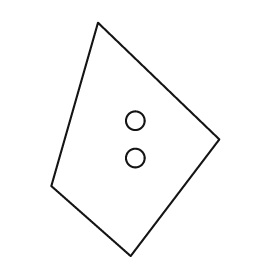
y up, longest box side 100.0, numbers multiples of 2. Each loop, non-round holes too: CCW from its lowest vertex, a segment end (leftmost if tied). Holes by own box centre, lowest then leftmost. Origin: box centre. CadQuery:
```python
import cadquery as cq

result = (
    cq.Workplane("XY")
    .moveTo(-2.0, -50.0)
    .lineTo(36.0, 0.0)
    .lineTo(-16.0, 50.0)
    .lineTo(-36.0, -20.0)
    .close()
    .moveTo(0.0, -8.0)
    .circle(4.0)
    .moveTo(0.0, 8.0)
    .circle(4.0)
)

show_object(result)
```